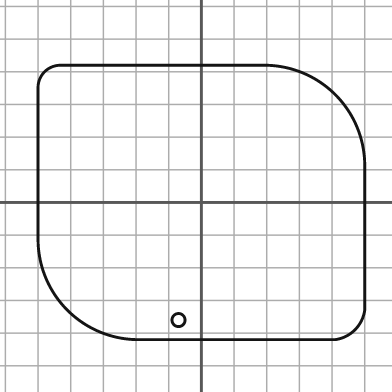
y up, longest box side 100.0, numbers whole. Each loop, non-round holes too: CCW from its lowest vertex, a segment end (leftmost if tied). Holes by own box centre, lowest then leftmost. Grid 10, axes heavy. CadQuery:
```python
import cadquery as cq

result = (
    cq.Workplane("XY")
    .moveTo(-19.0, -42.0)
    .lineTo(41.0, -42.0)
    .threePointArc((47.0, -39.0), (50.0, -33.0))
    .lineTo(50.0, 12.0)
    .threePointArc((41.0, 33.0), (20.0, 42.0))
    .lineTo(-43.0, 42.0)
    .threePointArc((-48.0, 40.0), (-50.0, 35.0))
    .lineTo(-50.0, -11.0)
    .threePointArc((-41.0, -33.0), (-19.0, -42.0))
    .close()
    .moveTo(-7.0, -36.0)
    .circle(2.0)
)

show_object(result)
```